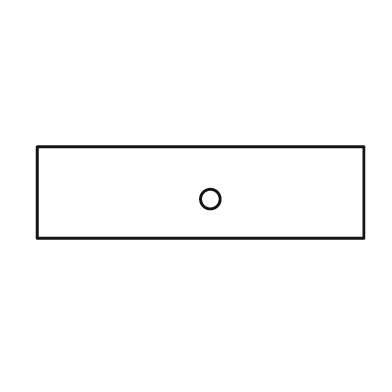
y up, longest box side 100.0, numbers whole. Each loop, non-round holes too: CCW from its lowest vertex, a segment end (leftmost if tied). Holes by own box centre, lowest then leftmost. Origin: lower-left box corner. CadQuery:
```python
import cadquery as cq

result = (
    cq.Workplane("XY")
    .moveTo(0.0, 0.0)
    .lineTo(100.0, 0.0)
    .lineTo(100.0, 28.0)
    .lineTo(0.0, 28.0)
    .close()
    .moveTo(53.0, 12.0)
    .circle(3.0)
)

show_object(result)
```